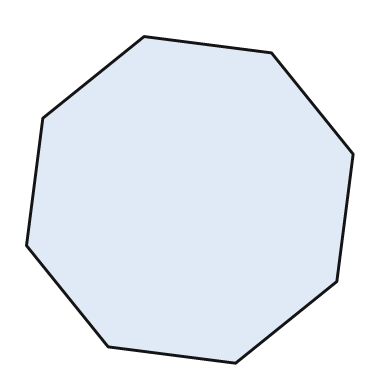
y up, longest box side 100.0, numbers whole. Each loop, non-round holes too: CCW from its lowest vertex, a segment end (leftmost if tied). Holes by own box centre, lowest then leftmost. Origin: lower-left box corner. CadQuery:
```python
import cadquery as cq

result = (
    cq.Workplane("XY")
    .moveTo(64.0, 0.0)
    .lineTo(95.0, 25.0)
    .lineTo(100.0, 64.0)
    .lineTo(75.0, 95.0)
    .lineTo(36.0, 100.0)
    .lineTo(5.0, 75.0)
    .lineTo(0.0, 36.0)
    .lineTo(25.0, 5.0)
    .close()
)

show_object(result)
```